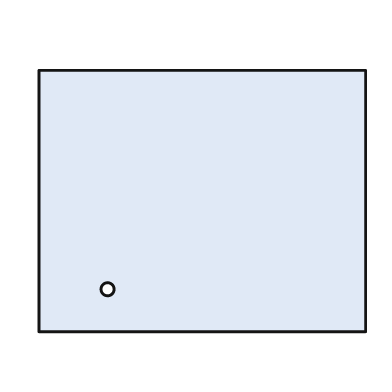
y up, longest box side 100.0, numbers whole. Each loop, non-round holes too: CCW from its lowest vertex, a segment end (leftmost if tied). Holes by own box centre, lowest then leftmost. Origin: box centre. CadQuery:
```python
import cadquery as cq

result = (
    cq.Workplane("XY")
    .moveTo(-50.0, -40.0)
    .lineTo(50.0, -40.0)
    .lineTo(50.0, 40.0)
    .lineTo(-50.0, 40.0)
    .close()
    .moveTo(-29.0, -27.0)
    .circle(2.0)
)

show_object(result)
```